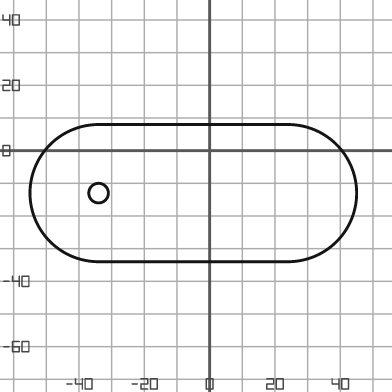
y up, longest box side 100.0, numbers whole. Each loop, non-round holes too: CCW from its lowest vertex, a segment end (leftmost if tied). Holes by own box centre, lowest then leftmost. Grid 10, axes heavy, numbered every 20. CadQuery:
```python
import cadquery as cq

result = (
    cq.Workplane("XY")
    .moveTo(-34.0, -34.0)
    .lineTo(24.0, -34.0)
    .threePointArc((45.0, -13.0), (24.0, 8.0))
    .lineTo(-34.0, 8.0)
    .threePointArc((-55.0, -13.0), (-34.0, -34.0))
    .close()
    .moveTo(-34.0, -13.0)
    .circle(3.0)
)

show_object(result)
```